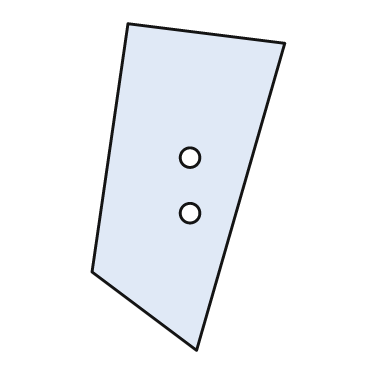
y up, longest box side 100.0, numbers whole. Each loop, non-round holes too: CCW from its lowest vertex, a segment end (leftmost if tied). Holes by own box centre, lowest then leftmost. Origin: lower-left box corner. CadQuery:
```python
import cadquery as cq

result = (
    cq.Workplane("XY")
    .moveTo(32.0, 0.0)
    .lineTo(59.0, 94.0)
    .lineTo(11.0, 100.0)
    .lineTo(0.0, 24.0)
    .close()
    .moveTo(30.0, 42.0)
    .circle(3.0)
    .moveTo(30.0, 59.0)
    .circle(3.0)
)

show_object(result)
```